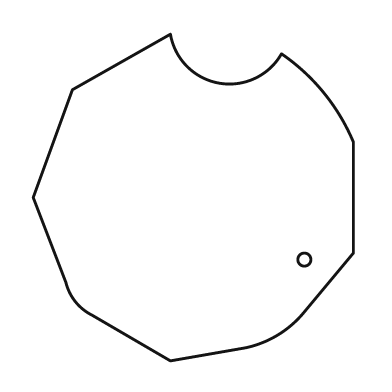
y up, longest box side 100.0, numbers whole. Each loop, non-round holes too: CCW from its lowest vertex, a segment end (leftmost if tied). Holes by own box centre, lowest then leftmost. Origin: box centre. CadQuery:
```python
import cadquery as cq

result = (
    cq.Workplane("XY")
    .moveTo(-7.0, -50.0)
    .lineTo(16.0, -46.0)
    .threePointArc((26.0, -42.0), (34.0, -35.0))
    .lineTo(49.0, -17.0)
    .lineTo(49.0, 17.0)
    .threePointArc((40.0, 32.0), (27.0, 44.0))
    .threePointArc((8.0, 35.0), (-7.0, 50.0))
    .lineTo(-37.0, 33.0)
    .lineTo(-49.0, 0.0)
    .lineTo(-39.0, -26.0)
    .threePointArc((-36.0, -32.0), (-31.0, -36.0))
    .close()
    .moveTo(34.0, -19.0)
    .circle(2.0)
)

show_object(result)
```